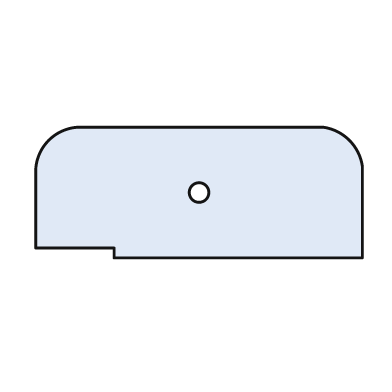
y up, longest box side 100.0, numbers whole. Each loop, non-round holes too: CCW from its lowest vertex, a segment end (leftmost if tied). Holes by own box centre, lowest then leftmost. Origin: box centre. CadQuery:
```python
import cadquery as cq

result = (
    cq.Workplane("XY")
    .moveTo(-26.0, -20.0)
    .lineTo(50.0, -20.0)
    .lineTo(50.0, 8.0)
    .threePointArc((46.0, 16.0), (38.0, 20.0))
    .lineTo(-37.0, 20.0)
    .threePointArc((-46.0, 16.0), (-50.0, 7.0))
    .lineTo(-50.0, -17.0)
    .lineTo(-26.0, -17.0)
    .close()
    .moveTo(0.0, 0.0)
    .circle(3.0)
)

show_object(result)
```